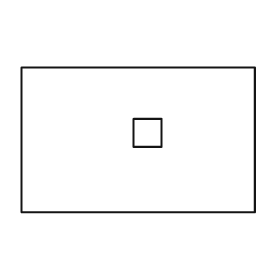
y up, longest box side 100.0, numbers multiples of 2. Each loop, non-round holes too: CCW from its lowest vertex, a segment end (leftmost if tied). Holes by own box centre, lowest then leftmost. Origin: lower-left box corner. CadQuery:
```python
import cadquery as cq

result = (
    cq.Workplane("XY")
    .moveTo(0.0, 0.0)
    .lineTo(100.0, 0.0)
    .lineTo(100.0, 62.0)
    .lineTo(0.0, 62.0)
    .close()
    .moveTo(48.0, 28.0)
    .lineTo(60.0, 28.0)
    .lineTo(60.0, 40.0)
    .lineTo(48.0, 40.0)
    .close()
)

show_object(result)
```